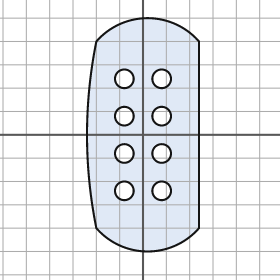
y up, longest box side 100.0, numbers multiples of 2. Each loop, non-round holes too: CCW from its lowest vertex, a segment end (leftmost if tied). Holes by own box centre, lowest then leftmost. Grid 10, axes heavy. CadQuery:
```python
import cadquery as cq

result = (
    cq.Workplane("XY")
    .moveTo(-20.0, -40.0)
    .threePointArc((2.0, -50.0), (24.0, -40.0))
    .lineTo(24.0, 40.0)
    .threePointArc((2.0, 50.0), (-20.0, 40.0))
    .threePointArc((-24.0, 0.0), (-20.0, -40.0))
    .close()
    .moveTo(-8.0, -24.0)
    .circle(4.0)
    .moveTo(8.0, -24.0)
    .circle(4.0)
    .moveTo(-8.0, -8.0)
    .circle(4.0)
    .moveTo(8.0, -8.0)
    .circle(4.0)
    .moveTo(-8.0, 8.0)
    .circle(4.0)
    .moveTo(8.0, 8.0)
    .circle(4.0)
    .moveTo(-8.0, 24.0)
    .circle(4.0)
    .moveTo(8.0, 24.0)
    .circle(4.0)
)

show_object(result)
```